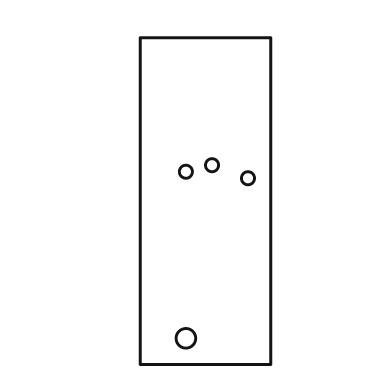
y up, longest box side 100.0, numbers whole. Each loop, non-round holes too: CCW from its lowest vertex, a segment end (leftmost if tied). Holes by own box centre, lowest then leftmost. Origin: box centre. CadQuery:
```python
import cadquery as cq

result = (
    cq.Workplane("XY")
    .moveTo(-20.0, -50.0)
    .lineTo(20.0, -50.0)
    .lineTo(20.0, 50.0)
    .lineTo(-20.0, 50.0)
    .close()
    .moveTo(-6.0, -42.0)
    .circle(3.0)
    .moveTo(13.0, 7.0)
    .circle(2.0)
    .moveTo(-6.0, 9.0)
    .circle(2.0)
    .moveTo(2.0, 11.0)
    .circle(2.0)
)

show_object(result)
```